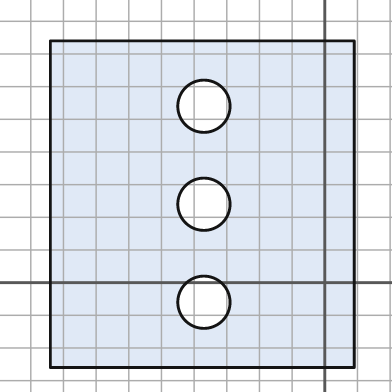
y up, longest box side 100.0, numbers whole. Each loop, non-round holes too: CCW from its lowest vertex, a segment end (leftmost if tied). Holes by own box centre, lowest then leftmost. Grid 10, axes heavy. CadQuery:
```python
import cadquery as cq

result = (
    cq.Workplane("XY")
    .moveTo(-84.0, -26.0)
    .lineTo(9.0, -26.0)
    .lineTo(9.0, 74.0)
    .lineTo(-84.0, 74.0)
    .close()
    .moveTo(-37.0, -6.0)
    .circle(8.0)
    .moveTo(-37.0, 24.0)
    .circle(8.0)
    .moveTo(-37.0, 54.0)
    .circle(8.0)
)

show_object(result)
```